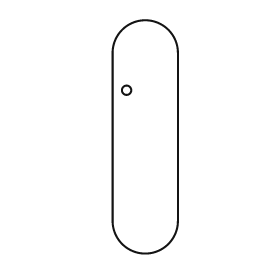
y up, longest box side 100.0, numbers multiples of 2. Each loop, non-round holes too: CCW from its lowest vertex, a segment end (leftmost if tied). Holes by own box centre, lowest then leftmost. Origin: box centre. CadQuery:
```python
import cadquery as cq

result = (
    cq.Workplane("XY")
    .moveTo(-14.0, -36.0)
    .threePointArc((0.0, -50.0), (14.0, -36.0))
    .lineTo(14.0, 36.0)
    .threePointArc((0.0, 50.0), (-14.0, 36.0))
    .close()
    .moveTo(-8.0, 20.0)
    .circle(2.0)
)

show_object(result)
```